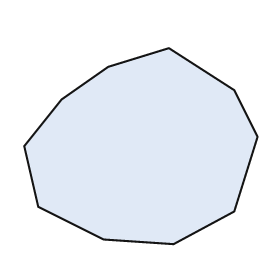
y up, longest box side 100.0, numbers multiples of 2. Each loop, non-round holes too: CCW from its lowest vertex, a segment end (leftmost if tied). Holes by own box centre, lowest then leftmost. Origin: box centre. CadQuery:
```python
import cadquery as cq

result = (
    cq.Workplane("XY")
    .moveTo(14.0, -42.0)
    .lineTo(40.0, -28.0)
    .lineTo(50.0, 4.0)
    .lineTo(40.0, 24.0)
    .lineTo(12.0, 42.0)
    .lineTo(-14.0, 34.0)
    .lineTo(-34.0, 20.0)
    .lineTo(-50.0, 0.0)
    .lineTo(-44.0, -26.0)
    .lineTo(-16.0, -40.0)
    .close()
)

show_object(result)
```